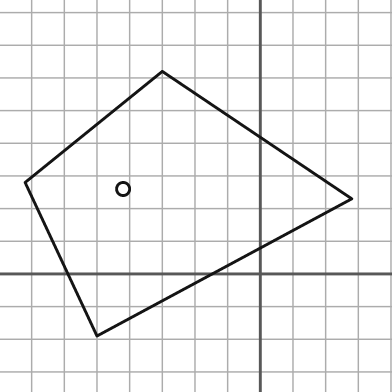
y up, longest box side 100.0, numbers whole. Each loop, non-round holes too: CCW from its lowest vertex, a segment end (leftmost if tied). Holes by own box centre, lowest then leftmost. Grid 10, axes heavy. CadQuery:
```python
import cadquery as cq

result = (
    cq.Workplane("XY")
    .moveTo(-50.0, -19.0)
    .lineTo(28.0, 23.0)
    .lineTo(-30.0, 62.0)
    .lineTo(-72.0, 28.0)
    .close()
    .moveTo(-42.0, 26.0)
    .circle(2.0)
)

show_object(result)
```